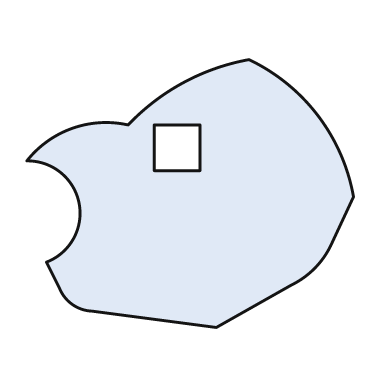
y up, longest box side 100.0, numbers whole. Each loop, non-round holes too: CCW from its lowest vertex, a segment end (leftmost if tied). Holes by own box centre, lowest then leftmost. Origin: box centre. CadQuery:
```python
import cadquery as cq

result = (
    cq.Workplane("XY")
    .moveTo(8.0, -41.0)
    .lineTo(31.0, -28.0)
    .threePointArc((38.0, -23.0), (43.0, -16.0))
    .lineTo(50.0, -1.0)
    .threePointArc((39.0, 24.0), (18.0, 41.0))
    .threePointArc((-2.0, 34.0), (-19.0, 21.0))
    .threePointArc((-36.0, 20.0), (-50.0, 10.0))
    .threePointArc((-34.0, -3.0), (-44.0, -21.0))
    .lineTo(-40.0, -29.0)
    .threePointArc((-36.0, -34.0), (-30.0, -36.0))
    .close()
    .moveTo(-11.0, 7.0)
    .lineTo(3.0, 7.0)
    .lineTo(3.0, 21.0)
    .lineTo(-11.0, 21.0)
    .close()
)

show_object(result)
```